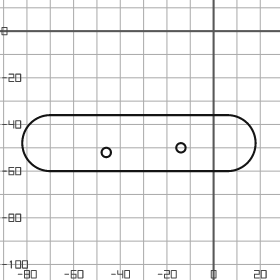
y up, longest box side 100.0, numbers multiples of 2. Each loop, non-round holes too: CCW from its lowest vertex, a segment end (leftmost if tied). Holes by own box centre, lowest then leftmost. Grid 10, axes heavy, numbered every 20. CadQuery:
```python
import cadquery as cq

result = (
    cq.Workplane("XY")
    .moveTo(-70.0, -60.0)
    .lineTo(6.0, -60.0)
    .threePointArc((18.0, -48.0), (6.0, -36.0))
    .lineTo(-70.0, -36.0)
    .threePointArc((-82.0, -48.0), (-70.0, -60.0))
    .close()
    .moveTo(-46.0, -52.0)
    .circle(2.0)
    .moveTo(-14.0, -50.0)
    .circle(2.0)
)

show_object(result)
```